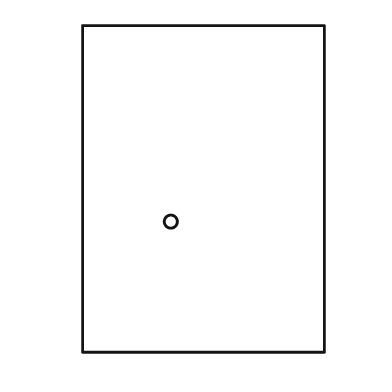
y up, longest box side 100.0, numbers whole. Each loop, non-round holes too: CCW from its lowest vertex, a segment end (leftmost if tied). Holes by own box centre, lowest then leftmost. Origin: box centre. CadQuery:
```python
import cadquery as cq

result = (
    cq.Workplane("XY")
    .moveTo(-37.0, -50.0)
    .lineTo(37.0, -50.0)
    .lineTo(37.0, 50.0)
    .lineTo(-37.0, 50.0)
    .close()
    .moveTo(-10.0, -10.0)
    .circle(2.0)
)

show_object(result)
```